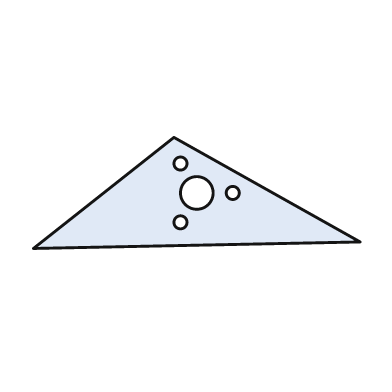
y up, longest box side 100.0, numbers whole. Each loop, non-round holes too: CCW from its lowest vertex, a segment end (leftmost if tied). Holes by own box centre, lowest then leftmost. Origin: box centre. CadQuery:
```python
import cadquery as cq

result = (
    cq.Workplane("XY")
    .moveTo(-50.0, -17.0)
    .lineTo(50.0, -15.0)
    .lineTo(-7.0, 17.0)
    .close()
    .moveTo(-5.0, -9.0)
    .circle(2.0)
    .moveTo(0.0, 0.0)
    .circle(5.0)
    .moveTo(11.0, 0.0)
    .circle(2.0)
    .moveTo(-5.0, 9.0)
    .circle(2.0)
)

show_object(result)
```